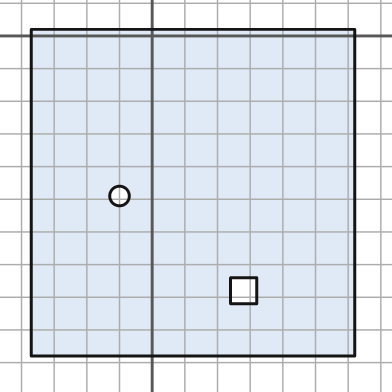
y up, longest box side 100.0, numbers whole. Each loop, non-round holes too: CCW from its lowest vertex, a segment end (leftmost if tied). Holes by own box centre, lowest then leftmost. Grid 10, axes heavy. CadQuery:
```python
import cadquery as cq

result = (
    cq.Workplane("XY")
    .moveTo(-37.0, -98.0)
    .lineTo(62.0, -98.0)
    .lineTo(62.0, 2.0)
    .lineTo(-37.0, 2.0)
    .close()
    .moveTo(24.0, -82.0)
    .lineTo(32.0, -82.0)
    .lineTo(32.0, -74.0)
    .lineTo(24.0, -74.0)
    .close()
    .moveTo(-10.0, -49.0)
    .circle(3.0)
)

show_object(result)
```